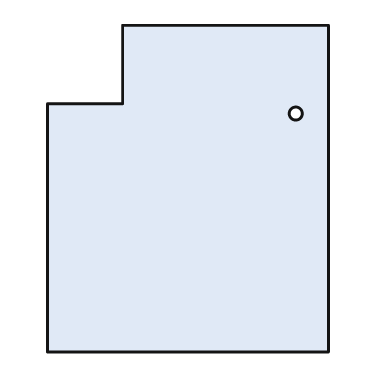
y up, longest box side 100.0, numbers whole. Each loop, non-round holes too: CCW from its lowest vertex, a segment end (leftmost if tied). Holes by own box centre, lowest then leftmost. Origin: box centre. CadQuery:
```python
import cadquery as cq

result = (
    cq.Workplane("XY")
    .moveTo(-43.0, -50.0)
    .lineTo(43.0, -50.0)
    .lineTo(43.0, 50.0)
    .lineTo(-20.0, 50.0)
    .lineTo(-20.0, 26.0)
    .lineTo(-43.0, 26.0)
    .close()
    .moveTo(33.0, 23.0)
    .circle(2.0)
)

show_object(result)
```